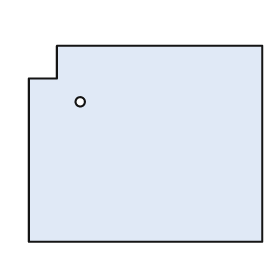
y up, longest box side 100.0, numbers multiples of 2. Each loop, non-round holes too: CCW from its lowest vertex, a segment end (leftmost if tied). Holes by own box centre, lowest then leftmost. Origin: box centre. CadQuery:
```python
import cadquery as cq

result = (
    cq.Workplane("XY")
    .moveTo(-50.0, -42.0)
    .lineTo(50.0, -42.0)
    .lineTo(50.0, 42.0)
    .lineTo(-38.0, 42.0)
    .lineTo(-38.0, 28.0)
    .lineTo(-50.0, 28.0)
    .close()
    .moveTo(-28.0, 18.0)
    .circle(2.0)
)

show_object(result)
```